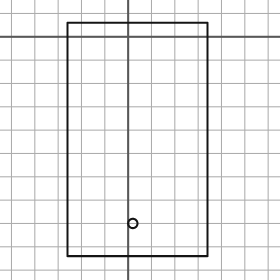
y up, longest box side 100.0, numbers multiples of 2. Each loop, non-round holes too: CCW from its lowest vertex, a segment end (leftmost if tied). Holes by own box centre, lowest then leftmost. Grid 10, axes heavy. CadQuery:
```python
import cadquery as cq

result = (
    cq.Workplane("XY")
    .moveTo(-26.0, -94.0)
    .lineTo(34.0, -94.0)
    .lineTo(34.0, 6.0)
    .lineTo(-26.0, 6.0)
    .close()
    .moveTo(2.0, -80.0)
    .circle(2.0)
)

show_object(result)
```